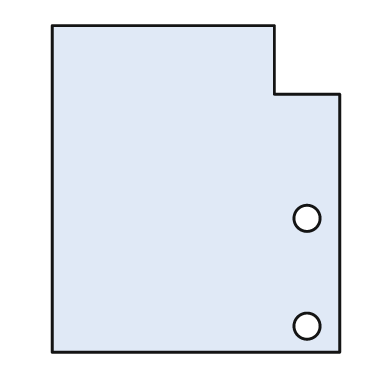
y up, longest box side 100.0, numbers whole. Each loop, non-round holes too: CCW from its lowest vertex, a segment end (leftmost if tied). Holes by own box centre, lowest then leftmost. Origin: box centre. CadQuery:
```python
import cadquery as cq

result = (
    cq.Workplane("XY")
    .moveTo(-44.0, -50.0)
    .lineTo(44.0, -50.0)
    .lineTo(44.0, 29.0)
    .lineTo(24.0, 29.0)
    .lineTo(24.0, 50.0)
    .lineTo(-44.0, 50.0)
    .close()
    .moveTo(34.0, -42.0)
    .circle(4.0)
    .moveTo(34.0, -9.0)
    .circle(4.0)
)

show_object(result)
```